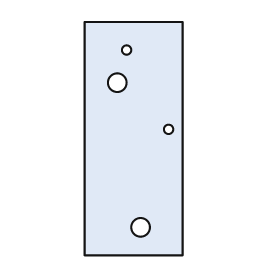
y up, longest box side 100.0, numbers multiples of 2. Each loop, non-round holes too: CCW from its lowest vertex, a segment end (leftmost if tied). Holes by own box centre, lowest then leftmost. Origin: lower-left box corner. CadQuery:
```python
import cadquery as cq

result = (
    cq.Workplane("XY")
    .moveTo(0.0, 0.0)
    .lineTo(42.0, 0.0)
    .lineTo(42.0, 100.0)
    .lineTo(0.0, 100.0)
    .close()
    .moveTo(24.0, 12.0)
    .circle(4.0)
    .moveTo(36.0, 54.0)
    .circle(2.0)
    .moveTo(14.0, 74.0)
    .circle(4.0)
    .moveTo(18.0, 88.0)
    .circle(2.0)
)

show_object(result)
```